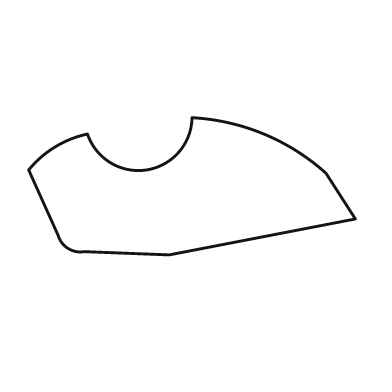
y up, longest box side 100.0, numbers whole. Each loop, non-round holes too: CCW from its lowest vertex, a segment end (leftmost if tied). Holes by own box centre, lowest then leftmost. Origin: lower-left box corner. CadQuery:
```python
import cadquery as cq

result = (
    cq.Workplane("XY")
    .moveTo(43.0, 0.0)
    .lineTo(100.0, 11.0)
    .lineTo(91.0, 25.0)
    .threePointArc((72.0, 37.0), (50.0, 42.0))
    .threePointArc((36.0, 26.0), (18.0, 37.0))
    .threePointArc((8.0, 33.0), (0.0, 26.0))
    .lineTo(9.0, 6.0)
    .threePointArc((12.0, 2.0), (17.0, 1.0))
    .close()
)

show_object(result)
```